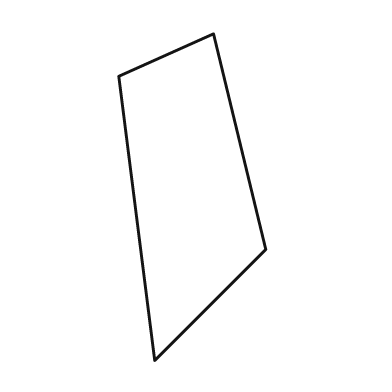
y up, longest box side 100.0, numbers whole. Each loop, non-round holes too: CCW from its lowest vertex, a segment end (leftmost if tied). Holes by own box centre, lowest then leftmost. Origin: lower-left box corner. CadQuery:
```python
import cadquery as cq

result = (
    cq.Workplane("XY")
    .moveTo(11.0, 0.0)
    .lineTo(45.0, 34.0)
    .lineTo(29.0, 100.0)
    .lineTo(0.0, 87.0)
    .close()
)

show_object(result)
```